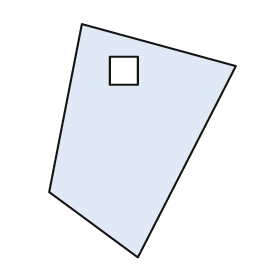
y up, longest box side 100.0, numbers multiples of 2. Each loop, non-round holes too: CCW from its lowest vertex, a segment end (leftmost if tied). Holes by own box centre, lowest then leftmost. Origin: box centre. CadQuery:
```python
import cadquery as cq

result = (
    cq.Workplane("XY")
    .moveTo(-2.0, -50.0)
    .lineTo(40.0, 32.0)
    .lineTo(-26.0, 50.0)
    .lineTo(-40.0, -22.0)
    .close()
    .moveTo(-14.0, 24.0)
    .lineTo(-2.0, 24.0)
    .lineTo(-2.0, 36.0)
    .lineTo(-14.0, 36.0)
    .close()
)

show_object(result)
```